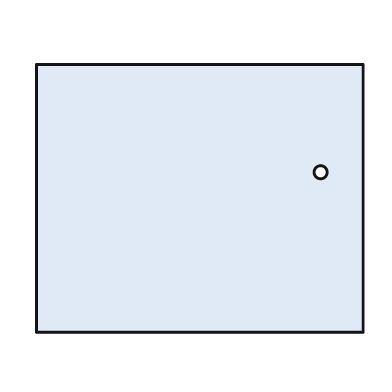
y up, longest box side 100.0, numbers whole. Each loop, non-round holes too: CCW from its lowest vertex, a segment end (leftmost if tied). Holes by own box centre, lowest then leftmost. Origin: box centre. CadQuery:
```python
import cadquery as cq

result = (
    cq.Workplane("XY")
    .moveTo(-50.0, -41.0)
    .lineTo(50.0, -41.0)
    .lineTo(50.0, 41.0)
    .lineTo(-50.0, 41.0)
    .close()
    .moveTo(37.0, 8.0)
    .circle(2.0)
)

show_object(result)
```